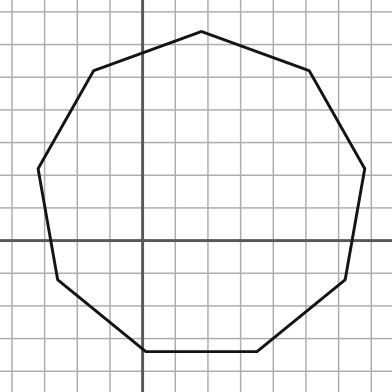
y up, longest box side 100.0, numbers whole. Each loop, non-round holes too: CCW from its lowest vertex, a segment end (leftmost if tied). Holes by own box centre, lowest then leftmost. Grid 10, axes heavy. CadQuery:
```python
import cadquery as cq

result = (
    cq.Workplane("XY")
    .moveTo(1.0, -34.0)
    .lineTo(35.0, -34.0)
    .lineTo(62.0, -12.0)
    .lineTo(68.0, 22.0)
    .lineTo(51.0, 52.0)
    .lineTo(18.0, 64.0)
    .lineTo(-15.0, 52.0)
    .lineTo(-32.0, 22.0)
    .lineTo(-26.0, -12.0)
    .close()
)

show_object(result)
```